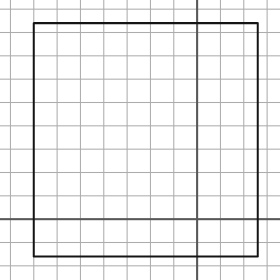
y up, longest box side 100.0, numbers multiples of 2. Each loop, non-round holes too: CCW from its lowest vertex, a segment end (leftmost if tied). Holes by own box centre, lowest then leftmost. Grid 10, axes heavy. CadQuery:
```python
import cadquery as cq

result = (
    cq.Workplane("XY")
    .moveTo(-70.0, -16.0)
    .lineTo(26.0, -16.0)
    .lineTo(26.0, 84.0)
    .lineTo(-70.0, 84.0)
    .close()
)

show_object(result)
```